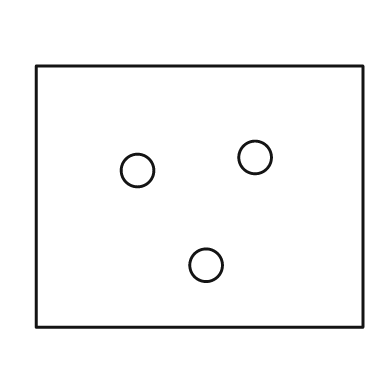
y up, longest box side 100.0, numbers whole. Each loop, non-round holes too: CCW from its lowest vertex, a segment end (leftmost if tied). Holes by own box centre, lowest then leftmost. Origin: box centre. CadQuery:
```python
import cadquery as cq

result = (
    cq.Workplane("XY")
    .moveTo(-50.0, -40.0)
    .lineTo(50.0, -40.0)
    .lineTo(50.0, 40.0)
    .lineTo(-50.0, 40.0)
    .close()
    .moveTo(2.0, -21.0)
    .circle(5.0)
    .moveTo(-19.0, 8.0)
    .circle(5.0)
    .moveTo(17.0, 12.0)
    .circle(5.0)
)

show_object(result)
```